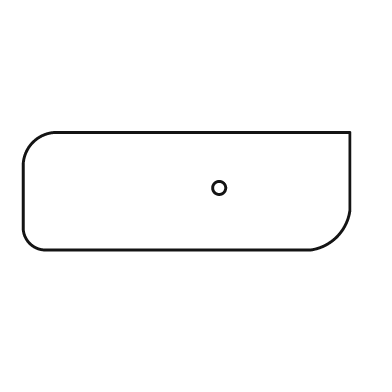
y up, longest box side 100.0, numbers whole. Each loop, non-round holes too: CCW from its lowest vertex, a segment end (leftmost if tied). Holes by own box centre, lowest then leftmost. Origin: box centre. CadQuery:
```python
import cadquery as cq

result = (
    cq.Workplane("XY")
    .moveTo(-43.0, -18.0)
    .lineTo(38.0, -18.0)
    .threePointArc((46.0, -14.0), (50.0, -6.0))
    .lineTo(50.0, 18.0)
    .lineTo(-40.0, 18.0)
    .threePointArc((-47.0, 15.0), (-50.0, 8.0))
    .lineTo(-50.0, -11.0)
    .threePointArc((-48.0, -16.0), (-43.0, -18.0))
    .close()
    .moveTo(10.0, 1.0)
    .circle(2.0)
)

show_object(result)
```